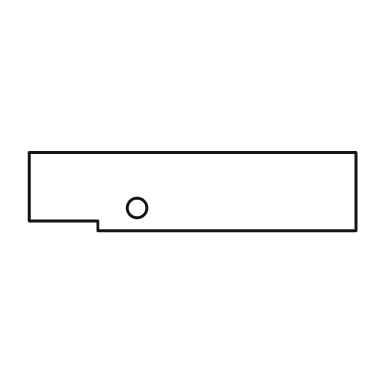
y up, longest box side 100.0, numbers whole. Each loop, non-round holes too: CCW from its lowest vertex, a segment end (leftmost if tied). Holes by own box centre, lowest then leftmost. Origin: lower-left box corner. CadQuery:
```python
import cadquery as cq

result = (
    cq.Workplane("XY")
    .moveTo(21.0, 0.0)
    .lineTo(100.0, 0.0)
    .lineTo(100.0, 24.0)
    .lineTo(0.0, 24.0)
    .lineTo(0.0, 3.0)
    .lineTo(21.0, 3.0)
    .close()
    .moveTo(33.0, 7.0)
    .circle(3.0)
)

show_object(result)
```